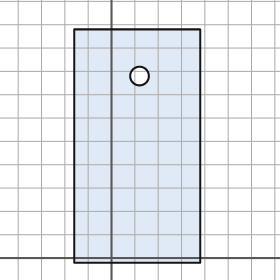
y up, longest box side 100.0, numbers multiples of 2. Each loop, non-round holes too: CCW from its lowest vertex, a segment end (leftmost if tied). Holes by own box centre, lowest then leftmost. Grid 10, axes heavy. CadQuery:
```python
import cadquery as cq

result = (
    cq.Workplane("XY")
    .moveTo(-16.0, -2.0)
    .lineTo(38.0, -2.0)
    .lineTo(38.0, 98.0)
    .lineTo(-16.0, 98.0)
    .close()
    .moveTo(12.0, 78.0)
    .circle(4.0)
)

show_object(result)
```